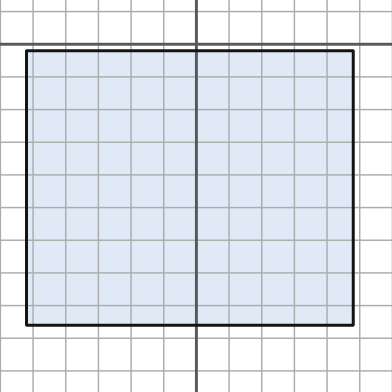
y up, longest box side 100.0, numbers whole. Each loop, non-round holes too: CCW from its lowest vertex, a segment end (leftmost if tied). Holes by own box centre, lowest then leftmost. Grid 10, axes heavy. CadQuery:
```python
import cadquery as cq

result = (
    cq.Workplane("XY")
    .moveTo(-52.0, -86.0)
    .lineTo(48.0, -86.0)
    .lineTo(48.0, -2.0)
    .lineTo(-52.0, -2.0)
    .close()
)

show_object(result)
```